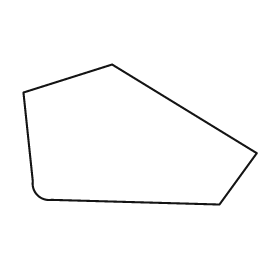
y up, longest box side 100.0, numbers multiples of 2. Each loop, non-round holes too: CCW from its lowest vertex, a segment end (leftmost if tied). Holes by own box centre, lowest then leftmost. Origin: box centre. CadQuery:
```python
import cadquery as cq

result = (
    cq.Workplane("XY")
    .moveTo(34.0, -30.0)
    .lineTo(50.0, -8.0)
    .lineTo(-12.0, 30.0)
    .lineTo(-50.0, 18.0)
    .lineTo(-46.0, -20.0)
    .threePointArc((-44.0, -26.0), (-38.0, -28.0))
    .close()
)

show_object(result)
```